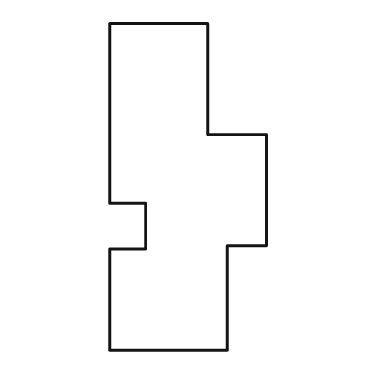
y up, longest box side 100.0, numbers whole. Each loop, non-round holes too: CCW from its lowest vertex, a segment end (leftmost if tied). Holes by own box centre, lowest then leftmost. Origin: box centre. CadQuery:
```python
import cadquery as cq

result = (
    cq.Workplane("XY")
    .moveTo(-24.0, -50.0)
    .lineTo(12.0, -50.0)
    .lineTo(12.0, -18.0)
    .lineTo(24.0, -18.0)
    .lineTo(24.0, 16.0)
    .lineTo(6.0, 16.0)
    .lineTo(6.0, 50.0)
    .lineTo(-24.0, 50.0)
    .lineTo(-24.0, -5.0)
    .lineTo(-13.0, -5.0)
    .lineTo(-13.0, -19.0)
    .lineTo(-24.0, -19.0)
    .close()
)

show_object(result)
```